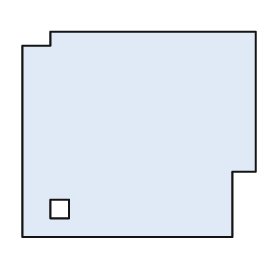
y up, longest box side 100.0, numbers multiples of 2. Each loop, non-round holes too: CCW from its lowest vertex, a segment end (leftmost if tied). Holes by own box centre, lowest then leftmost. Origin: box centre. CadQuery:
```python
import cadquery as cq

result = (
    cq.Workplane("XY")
    .moveTo(-50.0, -44.0)
    .lineTo(40.0, -44.0)
    .lineTo(40.0, -16.0)
    .lineTo(50.0, -16.0)
    .lineTo(50.0, 44.0)
    .lineTo(-38.0, 44.0)
    .lineTo(-38.0, 38.0)
    .lineTo(-50.0, 38.0)
    .close()
    .moveTo(-38.0, -36.0)
    .lineTo(-30.0, -36.0)
    .lineTo(-30.0, -28.0)
    .lineTo(-38.0, -28.0)
    .close()
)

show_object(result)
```